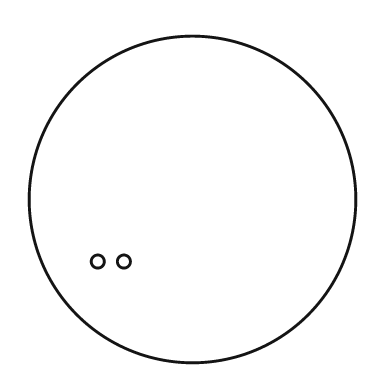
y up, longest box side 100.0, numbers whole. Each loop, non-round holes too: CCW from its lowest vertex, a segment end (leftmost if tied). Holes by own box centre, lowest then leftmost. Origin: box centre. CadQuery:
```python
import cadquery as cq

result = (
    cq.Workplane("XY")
    .moveTo(0.0, 0.0)
    .circle(50.0)
    .moveTo(-29.0, -19.0)
    .circle(2.0)
    .moveTo(-21.0, -19.0)
    .circle(2.0)
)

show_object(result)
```